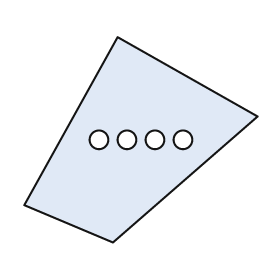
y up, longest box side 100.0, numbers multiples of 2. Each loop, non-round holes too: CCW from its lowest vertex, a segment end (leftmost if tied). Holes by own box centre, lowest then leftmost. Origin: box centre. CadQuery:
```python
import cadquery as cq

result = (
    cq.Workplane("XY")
    .moveTo(-12.0, -44.0)
    .lineTo(50.0, 10.0)
    .lineTo(-10.0, 44.0)
    .lineTo(-50.0, -28.0)
    .close()
    .moveTo(-18.0, 0.0)
    .circle(4.0)
    .moveTo(-6.0, 0.0)
    .circle(4.0)
    .moveTo(6.0, 0.0)
    .circle(4.0)
    .moveTo(18.0, 0.0)
    .circle(4.0)
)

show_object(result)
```